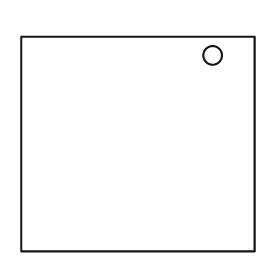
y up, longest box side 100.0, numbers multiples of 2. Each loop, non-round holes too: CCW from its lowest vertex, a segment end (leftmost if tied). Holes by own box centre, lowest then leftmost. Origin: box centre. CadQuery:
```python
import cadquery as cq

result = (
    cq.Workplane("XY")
    .moveTo(-50.0, -46.0)
    .lineTo(50.0, -46.0)
    .lineTo(50.0, 46.0)
    .lineTo(-50.0, 46.0)
    .close()
    .moveTo(32.0, 38.0)
    .circle(4.0)
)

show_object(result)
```